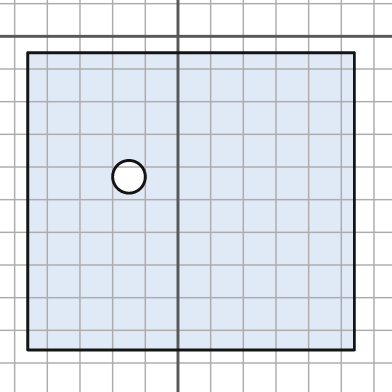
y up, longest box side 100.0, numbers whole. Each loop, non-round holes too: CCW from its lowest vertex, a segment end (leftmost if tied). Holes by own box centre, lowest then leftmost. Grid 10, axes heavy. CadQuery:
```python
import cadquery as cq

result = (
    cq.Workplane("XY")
    .moveTo(-46.0, -96.0)
    .lineTo(54.0, -96.0)
    .lineTo(54.0, -5.0)
    .lineTo(-46.0, -5.0)
    .close()
    .moveTo(-15.0, -43.0)
    .circle(5.0)
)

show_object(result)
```